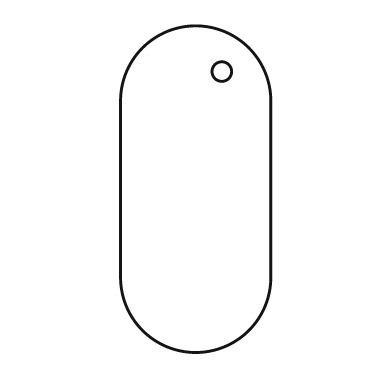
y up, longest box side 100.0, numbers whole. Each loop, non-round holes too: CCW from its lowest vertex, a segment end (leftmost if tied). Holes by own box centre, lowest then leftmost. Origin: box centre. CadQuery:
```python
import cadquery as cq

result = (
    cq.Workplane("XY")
    .moveTo(-23.0, -27.0)
    .threePointArc((0.0, -50.0), (23.0, -27.0))
    .lineTo(23.0, 27.0)
    .threePointArc((0.0, 50.0), (-23.0, 27.0))
    .close()
    .moveTo(8.0, 36.0)
    .circle(3.0)
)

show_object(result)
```